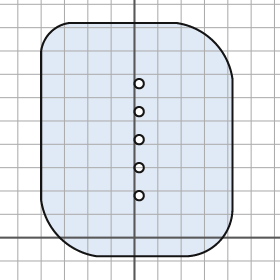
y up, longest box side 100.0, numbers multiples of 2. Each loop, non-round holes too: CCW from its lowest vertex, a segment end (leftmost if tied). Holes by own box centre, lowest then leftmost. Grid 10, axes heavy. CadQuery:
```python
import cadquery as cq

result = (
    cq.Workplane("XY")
    .moveTo(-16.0, -8.0)
    .lineTo(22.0, -8.0)
    .threePointArc((36.0, -2.0), (42.0, 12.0))
    .lineTo(42.0, 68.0)
    .threePointArc((34.0, 84.0), (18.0, 92.0))
    .lineTo(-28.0, 92.0)
    .threePointArc((-36.0, 88.0), (-40.0, 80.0))
    .lineTo(-40.0, 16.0)
    .threePointArc((-32.0, 0.0), (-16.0, -8.0))
    .close()
    .moveTo(2.0, 18.0)
    .circle(2.0)
    .moveTo(2.0, 30.0)
    .circle(2.0)
    .moveTo(2.0, 42.0)
    .circle(2.0)
    .moveTo(2.0, 54.0)
    .circle(2.0)
    .moveTo(2.0, 66.0)
    .circle(2.0)
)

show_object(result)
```